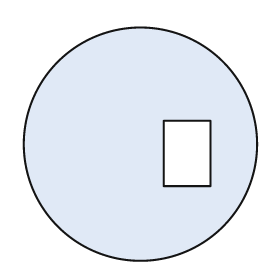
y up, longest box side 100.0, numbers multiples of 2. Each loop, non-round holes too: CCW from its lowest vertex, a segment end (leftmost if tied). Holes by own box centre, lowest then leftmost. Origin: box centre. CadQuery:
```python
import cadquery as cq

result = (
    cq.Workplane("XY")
    .moveTo(0.0, 0.0)
    .circle(50.0)
    .moveTo(10.0, -18.0)
    .lineTo(30.0, -18.0)
    .lineTo(30.0, 10.0)
    .lineTo(10.0, 10.0)
    .close()
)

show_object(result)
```